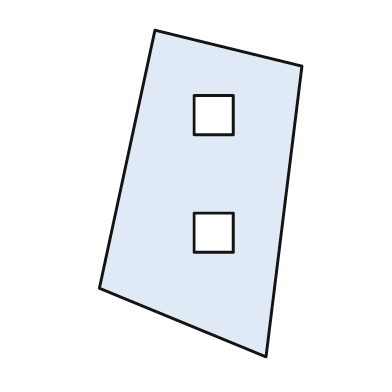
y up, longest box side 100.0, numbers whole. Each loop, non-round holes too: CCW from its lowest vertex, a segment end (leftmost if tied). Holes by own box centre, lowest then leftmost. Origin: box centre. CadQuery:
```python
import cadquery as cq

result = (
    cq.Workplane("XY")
    .moveTo(20.0, -50.0)
    .lineTo(31.0, 39.0)
    .lineTo(-14.0, 50.0)
    .lineTo(-31.0, -29.0)
    .close()
    .moveTo(-2.0, -18.0)
    .lineTo(10.0, -18.0)
    .lineTo(10.0, -6.0)
    .lineTo(-2.0, -6.0)
    .close()
    .moveTo(-2.0, 18.0)
    .lineTo(10.0, 18.0)
    .lineTo(10.0, 30.0)
    .lineTo(-2.0, 30.0)
    .close()
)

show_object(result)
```